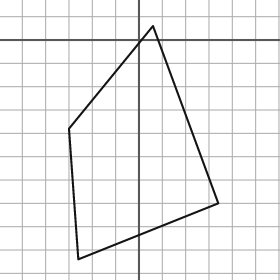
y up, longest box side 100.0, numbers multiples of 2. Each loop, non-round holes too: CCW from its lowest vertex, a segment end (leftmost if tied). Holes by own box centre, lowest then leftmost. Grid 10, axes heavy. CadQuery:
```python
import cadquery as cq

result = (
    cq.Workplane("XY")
    .moveTo(-26.0, -94.0)
    .lineTo(34.0, -70.0)
    .lineTo(6.0, 6.0)
    .lineTo(-30.0, -38.0)
    .close()
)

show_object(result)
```